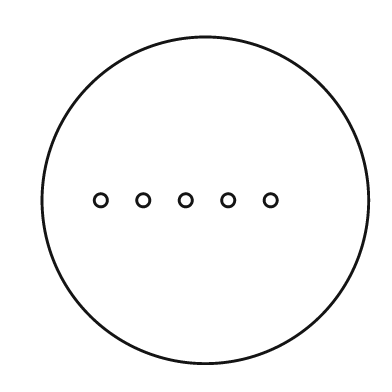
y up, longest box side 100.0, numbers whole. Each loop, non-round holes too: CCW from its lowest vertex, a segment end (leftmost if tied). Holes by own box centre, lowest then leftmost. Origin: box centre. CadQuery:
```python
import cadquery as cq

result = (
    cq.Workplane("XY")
    .moveTo(0.0, 0.0)
    .circle(50.0)
    .moveTo(-32.0, 0.0)
    .circle(2.0)
    .moveTo(-19.0, 0.0)
    .circle(2.0)
    .moveTo(-6.0, 0.0)
    .circle(2.0)
    .moveTo(7.0, 0.0)
    .circle(2.0)
    .moveTo(20.0, 0.0)
    .circle(2.0)
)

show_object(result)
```